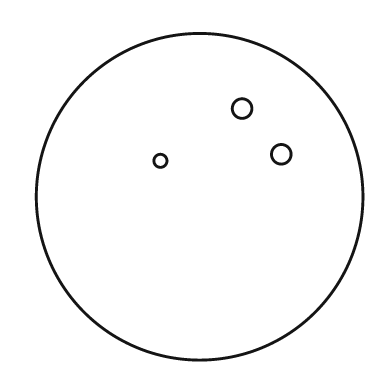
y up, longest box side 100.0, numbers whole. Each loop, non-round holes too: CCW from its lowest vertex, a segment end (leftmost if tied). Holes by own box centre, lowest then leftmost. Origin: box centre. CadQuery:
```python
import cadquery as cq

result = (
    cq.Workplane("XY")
    .moveTo(0.0, 0.0)
    .circle(50.0)
    .moveTo(-12.0, 11.0)
    .circle(2.0)
    .moveTo(25.0, 13.0)
    .circle(3.0)
    .moveTo(13.0, 27.0)
    .circle(3.0)
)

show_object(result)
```